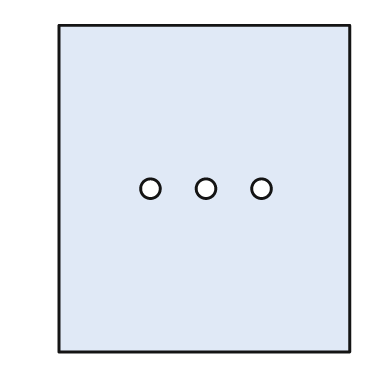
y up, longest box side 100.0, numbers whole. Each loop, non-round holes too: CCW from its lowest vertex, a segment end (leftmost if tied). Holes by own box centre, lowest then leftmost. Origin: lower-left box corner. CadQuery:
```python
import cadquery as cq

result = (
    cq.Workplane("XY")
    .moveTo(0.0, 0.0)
    .lineTo(89.0, 0.0)
    .lineTo(89.0, 100.0)
    .lineTo(0.0, 100.0)
    .close()
    .moveTo(28.0, 50.0)
    .circle(3.0)
    .moveTo(45.0, 50.0)
    .circle(3.0)
    .moveTo(62.0, 50.0)
    .circle(3.0)
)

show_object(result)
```